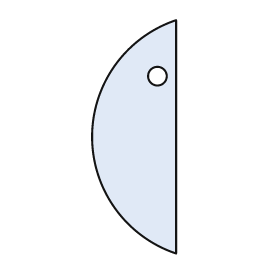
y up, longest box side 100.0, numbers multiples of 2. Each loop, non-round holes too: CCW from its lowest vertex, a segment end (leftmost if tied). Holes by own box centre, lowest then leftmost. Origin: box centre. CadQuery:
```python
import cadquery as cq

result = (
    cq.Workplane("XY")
    .moveTo(18.0, -50.0)
    .lineTo(18.0, 50.0)
    .threePointArc((-18.0, 0.0), (18.0, -50.0))
    .close()
    .moveTo(10.0, 26.0)
    .circle(4.0)
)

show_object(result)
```